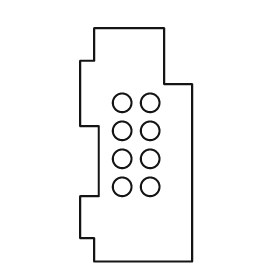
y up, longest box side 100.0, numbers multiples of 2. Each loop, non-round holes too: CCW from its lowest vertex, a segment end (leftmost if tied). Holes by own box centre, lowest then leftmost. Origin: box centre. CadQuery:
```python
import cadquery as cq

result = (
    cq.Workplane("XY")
    .moveTo(-18.0, -50.0)
    .lineTo(24.0, -50.0)
    .lineTo(24.0, 26.0)
    .lineTo(12.0, 26.0)
    .lineTo(12.0, 50.0)
    .lineTo(-18.0, 50.0)
    .lineTo(-18.0, 36.0)
    .lineTo(-24.0, 36.0)
    .lineTo(-24.0, 8.0)
    .lineTo(-16.0, 8.0)
    .lineTo(-16.0, -22.0)
    .lineTo(-24.0, -22.0)
    .lineTo(-24.0, -40.0)
    .lineTo(-18.0, -40.0)
    .close()
    .moveTo(-6.0, -18.0)
    .circle(4.0)
    .moveTo(6.0, -18.0)
    .circle(4.0)
    .moveTo(-6.0, -6.0)
    .circle(4.0)
    .moveTo(6.0, -6.0)
    .circle(4.0)
    .moveTo(-6.0, 6.0)
    .circle(4.0)
    .moveTo(6.0, 6.0)
    .circle(4.0)
    .moveTo(-6.0, 18.0)
    .circle(4.0)
    .moveTo(6.0, 18.0)
    .circle(4.0)
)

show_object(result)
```